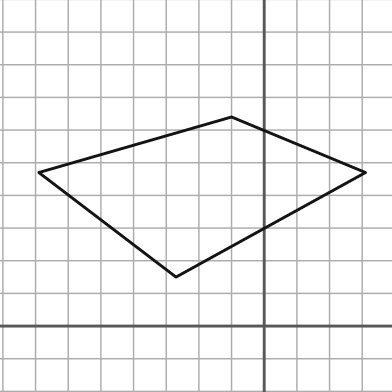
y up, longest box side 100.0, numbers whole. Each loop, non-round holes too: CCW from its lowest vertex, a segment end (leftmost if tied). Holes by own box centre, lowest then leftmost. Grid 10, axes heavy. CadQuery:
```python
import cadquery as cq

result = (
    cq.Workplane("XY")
    .moveTo(-27.0, 15.0)
    .lineTo(31.0, 47.0)
    .lineTo(-10.0, 64.0)
    .lineTo(-69.0, 47.0)
    .close()
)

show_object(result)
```